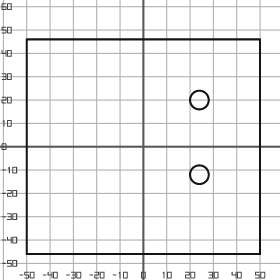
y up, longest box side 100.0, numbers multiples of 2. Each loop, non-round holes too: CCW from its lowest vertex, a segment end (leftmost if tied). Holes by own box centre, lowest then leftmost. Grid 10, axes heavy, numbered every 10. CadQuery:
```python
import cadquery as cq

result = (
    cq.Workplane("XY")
    .moveTo(-50.0, -46.0)
    .lineTo(50.0, -46.0)
    .lineTo(50.0, 46.0)
    .lineTo(-50.0, 46.0)
    .close()
    .moveTo(24.0, -12.0)
    .circle(4.0)
    .moveTo(24.0, 20.0)
    .circle(4.0)
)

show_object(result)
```